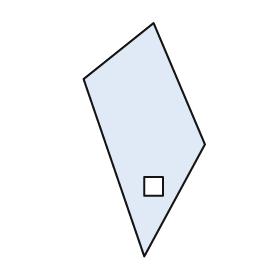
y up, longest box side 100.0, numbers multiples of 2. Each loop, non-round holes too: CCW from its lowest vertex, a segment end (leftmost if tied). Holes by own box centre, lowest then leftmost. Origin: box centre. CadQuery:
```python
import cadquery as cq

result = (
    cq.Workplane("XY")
    .moveTo(0.0, -50.0)
    .lineTo(26.0, -2.0)
    .lineTo(4.0, 50.0)
    .lineTo(-26.0, 26.0)
    .close()
    .moveTo(0.0, -24.0)
    .lineTo(8.0, -24.0)
    .lineTo(8.0, -16.0)
    .lineTo(0.0, -16.0)
    .close()
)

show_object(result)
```